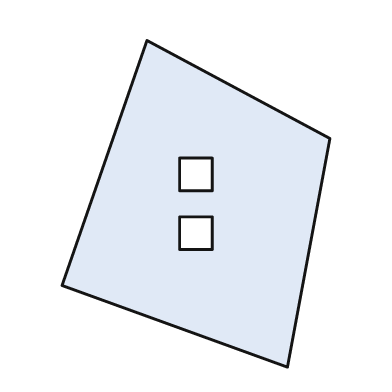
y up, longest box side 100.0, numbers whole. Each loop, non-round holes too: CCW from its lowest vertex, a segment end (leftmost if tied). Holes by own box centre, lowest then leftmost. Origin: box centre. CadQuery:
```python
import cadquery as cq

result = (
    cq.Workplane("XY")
    .moveTo(28.0, -50.0)
    .lineTo(41.0, 20.0)
    .lineTo(-15.0, 50.0)
    .lineTo(-41.0, -25.0)
    .close()
    .moveTo(-5.0, -14.0)
    .lineTo(5.0, -14.0)
    .lineTo(5.0, -4.0)
    .lineTo(-5.0, -4.0)
    .close()
    .moveTo(-5.0, 4.0)
    .lineTo(5.0, 4.0)
    .lineTo(5.0, 14.0)
    .lineTo(-5.0, 14.0)
    .close()
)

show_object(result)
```